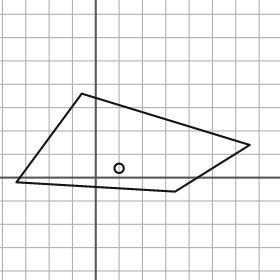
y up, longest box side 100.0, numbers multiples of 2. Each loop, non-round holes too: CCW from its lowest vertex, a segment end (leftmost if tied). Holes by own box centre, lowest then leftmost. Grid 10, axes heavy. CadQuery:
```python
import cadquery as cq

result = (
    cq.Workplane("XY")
    .moveTo(34.0, -6.0)
    .lineTo(66.0, 14.0)
    .lineTo(-6.0, 36.0)
    .lineTo(-34.0, -2.0)
    .close()
    .moveTo(10.0, 4.0)
    .circle(2.0)
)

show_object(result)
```